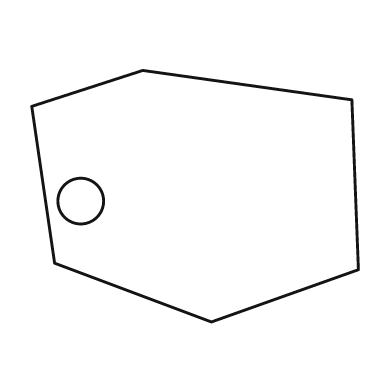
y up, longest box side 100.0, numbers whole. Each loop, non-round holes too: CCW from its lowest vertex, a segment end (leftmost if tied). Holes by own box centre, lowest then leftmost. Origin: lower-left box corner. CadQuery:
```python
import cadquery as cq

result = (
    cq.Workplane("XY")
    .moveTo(55.0, 0.0)
    .lineTo(100.0, 16.0)
    .lineTo(98.0, 68.0)
    .lineTo(34.0, 77.0)
    .lineTo(0.0, 66.0)
    .lineTo(7.0, 18.0)
    .close()
    .moveTo(15.0, 37.0)
    .circle(7.0)
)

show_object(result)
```